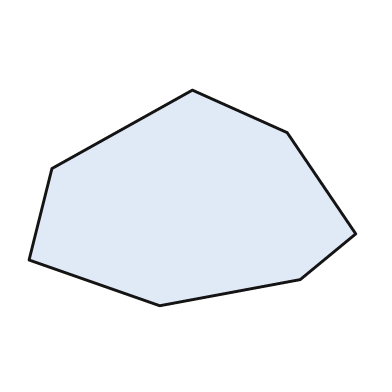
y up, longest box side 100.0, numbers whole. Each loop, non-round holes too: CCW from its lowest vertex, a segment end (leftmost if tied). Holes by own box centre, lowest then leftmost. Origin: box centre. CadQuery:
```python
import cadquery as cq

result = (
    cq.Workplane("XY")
    .moveTo(-10.0, -33.0)
    .lineTo(33.0, -25.0)
    .lineTo(50.0, -11.0)
    .lineTo(29.0, 20.0)
    .lineTo(0.0, 33.0)
    .lineTo(-43.0, 9.0)
    .lineTo(-50.0, -19.0)
    .close()
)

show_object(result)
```